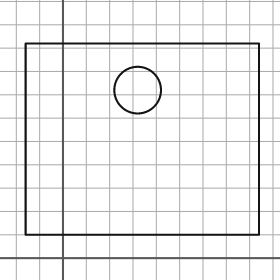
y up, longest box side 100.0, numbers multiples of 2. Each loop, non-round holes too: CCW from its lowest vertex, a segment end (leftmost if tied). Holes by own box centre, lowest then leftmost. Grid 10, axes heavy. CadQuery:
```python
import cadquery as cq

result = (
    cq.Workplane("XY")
    .moveTo(-16.0, 10.0)
    .lineTo(84.0, 10.0)
    .lineTo(84.0, 92.0)
    .lineTo(-16.0, 92.0)
    .close()
    .moveTo(32.0, 72.0)
    .circle(10.0)
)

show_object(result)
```